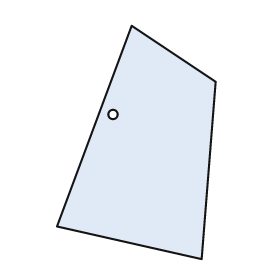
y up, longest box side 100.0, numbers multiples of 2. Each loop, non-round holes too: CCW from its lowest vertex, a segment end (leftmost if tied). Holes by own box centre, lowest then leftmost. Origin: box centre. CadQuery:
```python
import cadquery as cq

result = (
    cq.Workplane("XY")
    .moveTo(28.0, -50.0)
    .lineTo(34.0, 26.0)
    .lineTo(-2.0, 50.0)
    .lineTo(-34.0, -36.0)
    .close()
    .moveTo(-10.0, 12.0)
    .circle(2.0)
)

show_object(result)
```